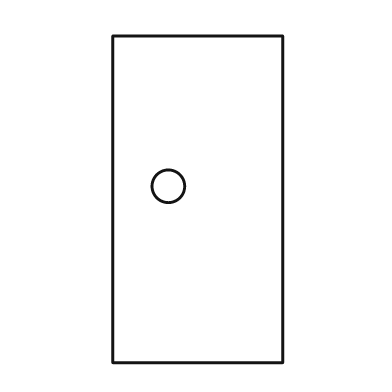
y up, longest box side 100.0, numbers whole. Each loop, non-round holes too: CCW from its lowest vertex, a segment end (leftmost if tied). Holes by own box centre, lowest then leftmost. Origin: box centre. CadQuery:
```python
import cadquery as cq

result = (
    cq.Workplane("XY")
    .moveTo(-26.0, -50.0)
    .lineTo(26.0, -50.0)
    .lineTo(26.0, 50.0)
    .lineTo(-26.0, 50.0)
    .close()
    .moveTo(-9.0, 4.0)
    .circle(5.0)
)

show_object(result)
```